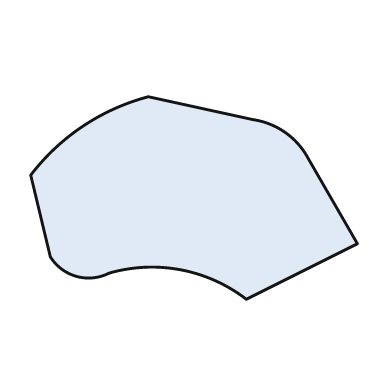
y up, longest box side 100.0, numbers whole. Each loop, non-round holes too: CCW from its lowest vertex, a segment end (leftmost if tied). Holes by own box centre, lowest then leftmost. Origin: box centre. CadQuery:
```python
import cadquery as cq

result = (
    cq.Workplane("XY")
    .moveTo(16.0, -31.0)
    .lineTo(50.0, -14.0)
    .lineTo(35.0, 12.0)
    .threePointArc((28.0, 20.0), (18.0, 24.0))
    .lineTo(-14.0, 31.0)
    .threePointArc((-34.0, 22.0), (-50.0, 7.0))
    .lineTo(-44.0, -18.0)
    .threePointArc((-36.0, -24.0), (-26.0, -23.0))
    .threePointArc((-4.0, -22.0), (16.0, -31.0))
    .close()
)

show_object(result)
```